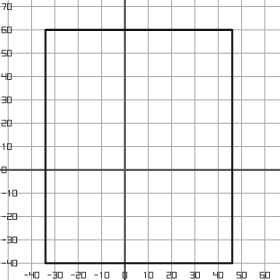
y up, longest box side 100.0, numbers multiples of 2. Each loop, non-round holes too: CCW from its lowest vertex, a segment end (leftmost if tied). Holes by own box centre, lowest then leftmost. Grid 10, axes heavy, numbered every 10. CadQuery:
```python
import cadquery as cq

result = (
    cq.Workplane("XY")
    .moveTo(-34.0, -40.0)
    .lineTo(46.0, -40.0)
    .lineTo(46.0, 60.0)
    .lineTo(-34.0, 60.0)
    .close()
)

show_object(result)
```